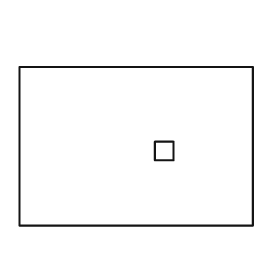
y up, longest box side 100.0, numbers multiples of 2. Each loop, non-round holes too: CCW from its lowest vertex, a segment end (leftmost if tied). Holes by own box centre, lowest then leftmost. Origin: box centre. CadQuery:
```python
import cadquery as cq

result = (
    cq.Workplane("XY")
    .moveTo(-50.0, -34.0)
    .lineTo(50.0, -34.0)
    .lineTo(50.0, 34.0)
    .lineTo(-50.0, 34.0)
    .close()
    .moveTo(8.0, -6.0)
    .lineTo(16.0, -6.0)
    .lineTo(16.0, 2.0)
    .lineTo(8.0, 2.0)
    .close()
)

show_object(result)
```